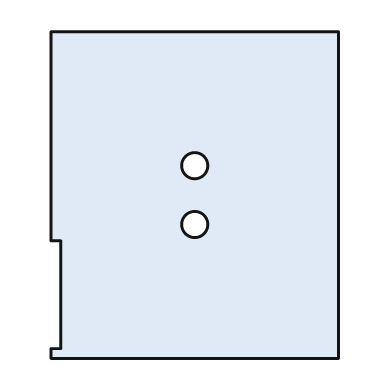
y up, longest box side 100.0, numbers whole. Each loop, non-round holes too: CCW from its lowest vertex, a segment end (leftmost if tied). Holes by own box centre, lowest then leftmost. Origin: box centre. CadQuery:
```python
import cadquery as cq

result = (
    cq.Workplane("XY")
    .moveTo(-44.0, -50.0)
    .lineTo(44.0, -50.0)
    .lineTo(44.0, 50.0)
    .lineTo(-44.0, 50.0)
    .lineTo(-44.0, -14.0)
    .lineTo(-41.0, -14.0)
    .lineTo(-41.0, -47.0)
    .lineTo(-44.0, -47.0)
    .close()
    .moveTo(0.0, -9.0)
    .circle(4.0)
    .moveTo(0.0, 9.0)
    .circle(4.0)
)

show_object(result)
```